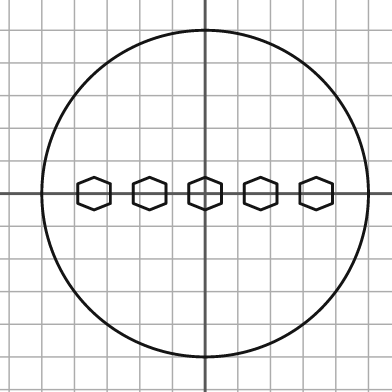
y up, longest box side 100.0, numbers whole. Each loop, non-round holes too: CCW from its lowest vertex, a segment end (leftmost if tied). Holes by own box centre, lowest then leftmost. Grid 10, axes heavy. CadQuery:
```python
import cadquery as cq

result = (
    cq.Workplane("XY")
    .moveTo(0.0, 0.0)
    .circle(50.0)
    .moveTo(-34.0, -5.0)
    .lineTo(-29.0, -3.0)
    .lineTo(-29.0, 3.0)
    .lineTo(-34.0, 5.0)
    .lineTo(-39.0, 3.0)
    .lineTo(-39.0, -3.0)
    .close()
    .moveTo(-17.0, -5.0)
    .lineTo(-12.0, -3.0)
    .lineTo(-12.0, 3.0)
    .lineTo(-17.0, 5.0)
    .lineTo(-22.0, 3.0)
    .lineTo(-22.0, -3.0)
    .close()
    .moveTo(0.0, -5.0)
    .lineTo(5.0, -3.0)
    .lineTo(5.0, 3.0)
    .lineTo(0.0, 5.0)
    .lineTo(-5.0, 3.0)
    .lineTo(-5.0, -3.0)
    .close()
    .moveTo(17.0, -5.0)
    .lineTo(22.0, -3.0)
    .lineTo(22.0, 3.0)
    .lineTo(17.0, 5.0)
    .lineTo(12.0, 3.0)
    .lineTo(12.0, -3.0)
    .close()
    .moveTo(34.0, -5.0)
    .lineTo(39.0, -3.0)
    .lineTo(39.0, 3.0)
    .lineTo(34.0, 5.0)
    .lineTo(29.0, 3.0)
    .lineTo(29.0, -3.0)
    .close()
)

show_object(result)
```